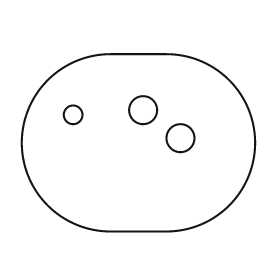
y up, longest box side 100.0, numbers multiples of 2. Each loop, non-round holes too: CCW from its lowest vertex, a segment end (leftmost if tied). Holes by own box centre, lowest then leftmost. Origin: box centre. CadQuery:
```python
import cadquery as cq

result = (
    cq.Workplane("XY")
    .moveTo(-12.0, -38.0)
    .lineTo(12.0, -38.0)
    .threePointArc((50.0, 0.0), (12.0, 38.0))
    .lineTo(-12.0, 38.0)
    .threePointArc((-50.0, 0.0), (-12.0, -38.0))
    .close()
    .moveTo(18.0, 2.0)
    .circle(6.0)
    .moveTo(-28.0, 12.0)
    .circle(4.0)
    .moveTo(2.0, 14.0)
    .circle(6.0)
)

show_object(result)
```